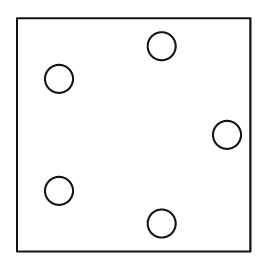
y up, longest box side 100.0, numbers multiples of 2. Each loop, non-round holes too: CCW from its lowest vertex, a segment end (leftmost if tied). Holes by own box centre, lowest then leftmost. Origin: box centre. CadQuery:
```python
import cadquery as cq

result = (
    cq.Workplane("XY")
    .moveTo(-50.0, -50.0)
    .lineTo(50.0, -50.0)
    .lineTo(50.0, 50.0)
    .lineTo(-50.0, 50.0)
    .close()
    .moveTo(12.0, -38.0)
    .circle(6.0)
    .moveTo(-32.0, -24.0)
    .circle(6.0)
    .moveTo(40.0, 0.0)
    .circle(6.0)
    .moveTo(-32.0, 24.0)
    .circle(6.0)
    .moveTo(12.0, 38.0)
    .circle(6.0)
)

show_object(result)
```